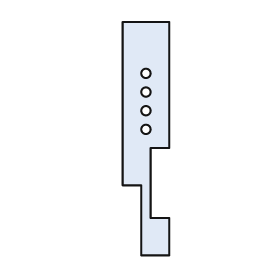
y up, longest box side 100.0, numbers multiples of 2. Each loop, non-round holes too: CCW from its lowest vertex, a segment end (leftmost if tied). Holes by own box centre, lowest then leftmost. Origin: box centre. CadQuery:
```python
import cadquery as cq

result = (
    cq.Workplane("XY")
    .moveTo(-2.0, -50.0)
    .lineTo(10.0, -50.0)
    .lineTo(10.0, -34.0)
    .lineTo(2.0, -34.0)
    .lineTo(2.0, -4.0)
    .lineTo(10.0, -4.0)
    .lineTo(10.0, 50.0)
    .lineTo(-10.0, 50.0)
    .lineTo(-10.0, -20.0)
    .lineTo(-2.0, -20.0)
    .close()
    .moveTo(0.0, 4.0)
    .circle(2.0)
    .moveTo(0.0, 12.0)
    .circle(2.0)
    .moveTo(0.0, 20.0)
    .circle(2.0)
    .moveTo(0.0, 28.0)
    .circle(2.0)
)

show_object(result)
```